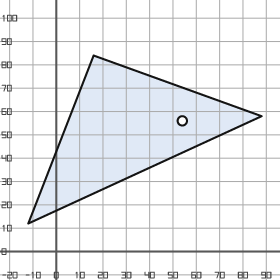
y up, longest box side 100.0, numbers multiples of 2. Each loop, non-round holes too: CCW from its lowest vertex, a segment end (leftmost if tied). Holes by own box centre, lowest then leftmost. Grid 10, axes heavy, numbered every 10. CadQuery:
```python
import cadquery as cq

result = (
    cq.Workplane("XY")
    .moveTo(-12.0, 12.0)
    .lineTo(88.0, 58.0)
    .lineTo(16.0, 84.0)
    .close()
    .moveTo(54.0, 56.0)
    .circle(2.0)
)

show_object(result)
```